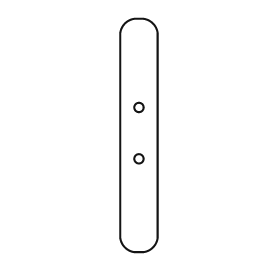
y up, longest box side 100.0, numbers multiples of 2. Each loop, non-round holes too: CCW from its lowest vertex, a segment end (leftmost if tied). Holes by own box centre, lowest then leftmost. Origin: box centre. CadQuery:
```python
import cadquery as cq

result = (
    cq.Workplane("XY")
    .moveTo(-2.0, -50.0)
    .lineTo(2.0, -50.0)
    .threePointArc((6.0, -48.0), (8.0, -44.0))
    .lineTo(8.0, 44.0)
    .threePointArc((6.0, 48.0), (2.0, 50.0))
    .lineTo(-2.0, 50.0)
    .threePointArc((-6.0, 48.0), (-8.0, 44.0))
    .lineTo(-8.0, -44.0)
    .threePointArc((-6.0, -48.0), (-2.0, -50.0))
    .close()
    .moveTo(0.0, -10.0)
    .circle(2.0)
    .moveTo(0.0, 12.0)
    .circle(2.0)
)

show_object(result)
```